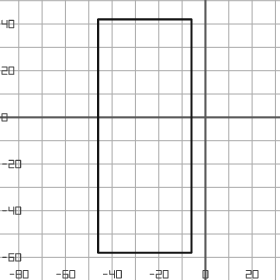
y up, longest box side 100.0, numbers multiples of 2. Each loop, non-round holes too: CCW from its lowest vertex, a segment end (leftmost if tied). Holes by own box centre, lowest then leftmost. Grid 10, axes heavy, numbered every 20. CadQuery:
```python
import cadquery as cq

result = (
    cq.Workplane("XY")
    .moveTo(-46.0, -58.0)
    .lineTo(-6.0, -58.0)
    .lineTo(-6.0, 42.0)
    .lineTo(-46.0, 42.0)
    .close()
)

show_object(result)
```